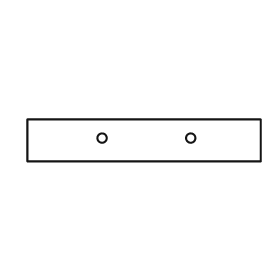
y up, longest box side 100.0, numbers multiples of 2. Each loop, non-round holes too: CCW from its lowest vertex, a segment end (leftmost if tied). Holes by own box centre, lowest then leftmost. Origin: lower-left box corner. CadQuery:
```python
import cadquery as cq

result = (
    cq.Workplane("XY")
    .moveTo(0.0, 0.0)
    .lineTo(100.0, 0.0)
    .lineTo(100.0, 18.0)
    .lineTo(0.0, 18.0)
    .close()
    .moveTo(32.0, 10.0)
    .circle(2.0)
    .moveTo(70.0, 10.0)
    .circle(2.0)
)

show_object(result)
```